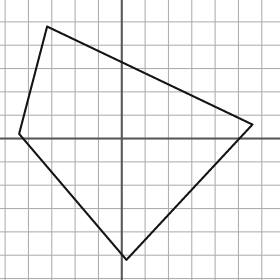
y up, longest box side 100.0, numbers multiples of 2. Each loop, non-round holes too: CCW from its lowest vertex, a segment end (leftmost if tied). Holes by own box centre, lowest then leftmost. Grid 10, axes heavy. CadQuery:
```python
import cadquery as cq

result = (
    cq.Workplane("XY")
    .moveTo(2.0, -52.0)
    .lineTo(56.0, 6.0)
    .lineTo(-32.0, 48.0)
    .lineTo(-44.0, 2.0)
    .close()
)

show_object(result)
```